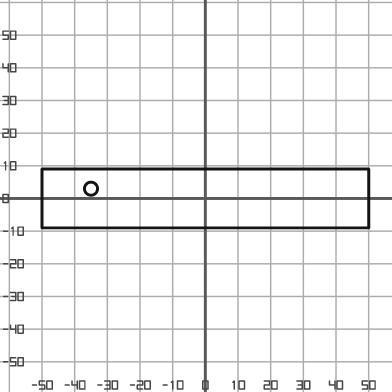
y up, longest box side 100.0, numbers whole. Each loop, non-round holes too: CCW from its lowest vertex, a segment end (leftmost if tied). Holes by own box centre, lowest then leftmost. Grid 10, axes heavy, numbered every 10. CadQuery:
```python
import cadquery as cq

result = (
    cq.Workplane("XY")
    .moveTo(-50.0, -9.0)
    .lineTo(50.0, -9.0)
    .lineTo(50.0, 9.0)
    .lineTo(-50.0, 9.0)
    .close()
    .moveTo(-35.0, 3.0)
    .circle(2.0)
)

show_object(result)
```